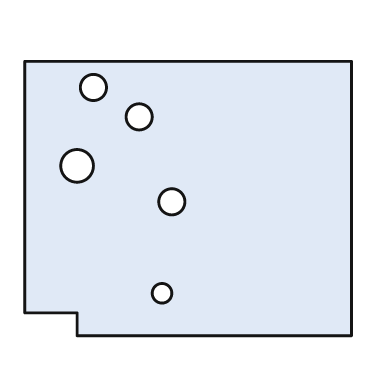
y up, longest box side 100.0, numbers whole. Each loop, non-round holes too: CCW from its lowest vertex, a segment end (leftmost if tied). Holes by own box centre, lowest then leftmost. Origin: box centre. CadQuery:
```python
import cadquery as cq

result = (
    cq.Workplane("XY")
    .moveTo(-34.0, -42.0)
    .lineTo(50.0, -42.0)
    .lineTo(50.0, 42.0)
    .lineTo(-50.0, 42.0)
    .lineTo(-50.0, -35.0)
    .lineTo(-34.0, -35.0)
    .close()
    .moveTo(-8.0, -29.0)
    .circle(3.0)
    .moveTo(-5.0, -1.0)
    .circle(4.0)
    .moveTo(-34.0, 10.0)
    .circle(5.0)
    .moveTo(-15.0, 25.0)
    .circle(4.0)
    .moveTo(-29.0, 34.0)
    .circle(4.0)
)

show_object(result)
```